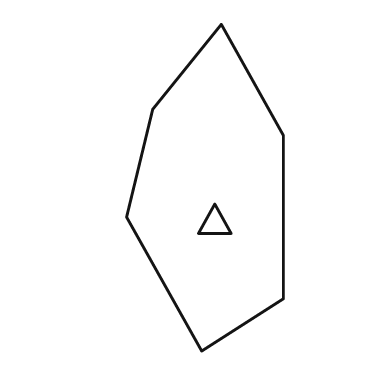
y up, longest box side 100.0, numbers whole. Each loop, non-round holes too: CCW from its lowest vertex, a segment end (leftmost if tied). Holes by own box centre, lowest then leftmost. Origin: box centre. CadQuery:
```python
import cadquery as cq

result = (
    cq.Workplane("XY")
    .moveTo(-1.0, -50.0)
    .lineTo(24.0, -34.0)
    .lineTo(24.0, 16.0)
    .lineTo(5.0, 50.0)
    .lineTo(-16.0, 24.0)
    .lineTo(-24.0, -9.0)
    .close()
    .moveTo(-2.0, -14.0)
    .lineTo(8.0, -14.0)
    .lineTo(3.0, -5.0)
    .close()
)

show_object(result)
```